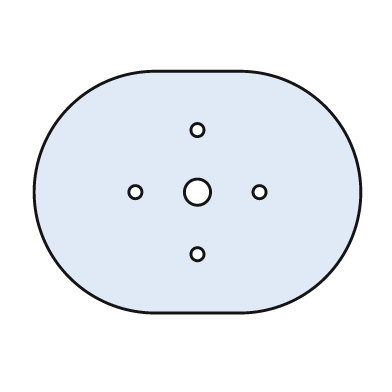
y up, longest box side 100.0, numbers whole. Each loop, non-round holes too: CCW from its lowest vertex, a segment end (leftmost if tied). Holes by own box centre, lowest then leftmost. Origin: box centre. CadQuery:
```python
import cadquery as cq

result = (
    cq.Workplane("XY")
    .moveTo(-13.0, -37.0)
    .lineTo(13.0, -37.0)
    .threePointArc((50.0, 0.0), (13.0, 37.0))
    .lineTo(-13.0, 37.0)
    .threePointArc((-50.0, 0.0), (-13.0, -37.0))
    .close()
    .moveTo(0.0, -19.0)
    .circle(2.0)
    .moveTo(-19.0, 0.0)
    .circle(2.0)
    .moveTo(0.0, 0.0)
    .circle(4.0)
    .moveTo(19.0, 0.0)
    .circle(2.0)
    .moveTo(0.0, 19.0)
    .circle(2.0)
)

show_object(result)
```